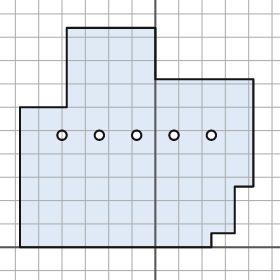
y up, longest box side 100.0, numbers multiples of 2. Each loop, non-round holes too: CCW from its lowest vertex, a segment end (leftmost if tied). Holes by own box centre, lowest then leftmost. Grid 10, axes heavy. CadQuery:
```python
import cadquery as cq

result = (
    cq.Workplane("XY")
    .moveTo(-58.0, 0.0)
    .lineTo(24.0, 0.0)
    .lineTo(24.0, 6.0)
    .lineTo(34.0, 6.0)
    .lineTo(34.0, 26.0)
    .lineTo(42.0, 26.0)
    .lineTo(42.0, 72.0)
    .lineTo(0.0, 72.0)
    .lineTo(0.0, 94.0)
    .lineTo(-38.0, 94.0)
    .lineTo(-38.0, 60.0)
    .lineTo(-58.0, 60.0)
    .close()
    .moveTo(-40.0, 48.0)
    .circle(2.0)
    .moveTo(-24.0, 48.0)
    .circle(2.0)
    .moveTo(-8.0, 48.0)
    .circle(2.0)
    .moveTo(8.0, 48.0)
    .circle(2.0)
    .moveTo(24.0, 48.0)
    .circle(2.0)
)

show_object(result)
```